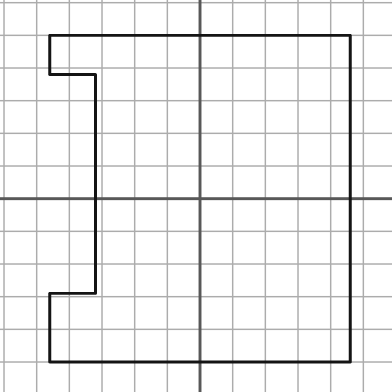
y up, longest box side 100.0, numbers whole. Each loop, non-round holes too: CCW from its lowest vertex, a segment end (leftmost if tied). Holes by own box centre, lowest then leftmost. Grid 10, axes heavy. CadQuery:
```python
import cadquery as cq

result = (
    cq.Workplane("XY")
    .moveTo(-46.0, -50.0)
    .lineTo(46.0, -50.0)
    .lineTo(46.0, 50.0)
    .lineTo(-46.0, 50.0)
    .lineTo(-46.0, 38.0)
    .lineTo(-32.0, 38.0)
    .lineTo(-32.0, -29.0)
    .lineTo(-46.0, -29.0)
    .close()
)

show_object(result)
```